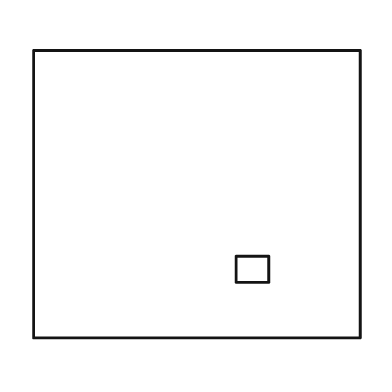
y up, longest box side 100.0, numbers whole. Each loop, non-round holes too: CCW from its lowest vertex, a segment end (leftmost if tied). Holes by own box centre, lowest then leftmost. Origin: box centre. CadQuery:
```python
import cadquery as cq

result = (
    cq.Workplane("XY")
    .moveTo(-50.0, -44.0)
    .lineTo(50.0, -44.0)
    .lineTo(50.0, 44.0)
    .lineTo(-50.0, 44.0)
    .close()
    .moveTo(12.0, -27.0)
    .lineTo(22.0, -27.0)
    .lineTo(22.0, -19.0)
    .lineTo(12.0, -19.0)
    .close()
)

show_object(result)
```